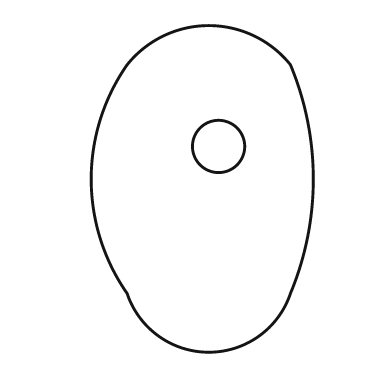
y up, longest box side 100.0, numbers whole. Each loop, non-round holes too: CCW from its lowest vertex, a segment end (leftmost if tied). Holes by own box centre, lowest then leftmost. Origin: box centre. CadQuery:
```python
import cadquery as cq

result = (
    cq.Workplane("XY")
    .moveTo(-23.0, -32.0)
    .threePointArc((2.0, -50.0), (27.0, -32.0))
    .threePointArc((34.0, 3.0), (27.0, 38.0))
    .threePointArc((2.0, 50.0), (-23.0, 38.0))
    .threePointArc((-34.0, 3.0), (-23.0, -32.0))
    .close()
    .moveTo(5.0, 13.0)
    .circle(8.0)
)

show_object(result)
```